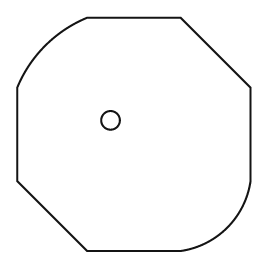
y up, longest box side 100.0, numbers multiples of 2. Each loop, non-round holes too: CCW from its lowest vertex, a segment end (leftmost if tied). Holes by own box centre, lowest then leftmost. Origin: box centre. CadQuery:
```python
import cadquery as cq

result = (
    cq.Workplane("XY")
    .moveTo(-20.0, -50.0)
    .lineTo(20.0, -50.0)
    .threePointArc((40.0, -40.0), (50.0, -20.0))
    .lineTo(50.0, 20.0)
    .lineTo(20.0, 50.0)
    .lineTo(-20.0, 50.0)
    .threePointArc((-38.0, 38.0), (-50.0, 20.0))
    .lineTo(-50.0, -20.0)
    .close()
    .moveTo(-10.0, 6.0)
    .circle(4.0)
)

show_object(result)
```